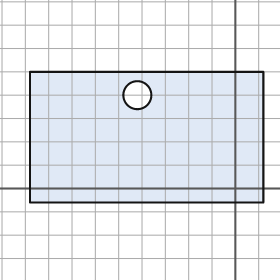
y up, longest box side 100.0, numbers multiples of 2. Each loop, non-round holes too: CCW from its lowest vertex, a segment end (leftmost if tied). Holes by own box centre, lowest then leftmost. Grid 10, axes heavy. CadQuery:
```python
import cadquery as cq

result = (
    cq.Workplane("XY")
    .moveTo(-88.0, -6.0)
    .lineTo(12.0, -6.0)
    .lineTo(12.0, 50.0)
    .lineTo(-88.0, 50.0)
    .close()
    .moveTo(-42.0, 40.0)
    .circle(6.0)
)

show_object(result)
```